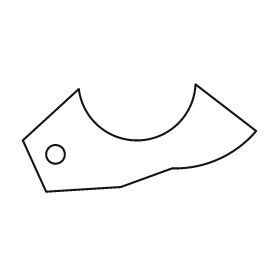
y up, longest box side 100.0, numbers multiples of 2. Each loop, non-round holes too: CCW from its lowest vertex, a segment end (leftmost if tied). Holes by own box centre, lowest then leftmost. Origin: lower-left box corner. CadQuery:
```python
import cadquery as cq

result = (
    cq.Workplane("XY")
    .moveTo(10.0, 0.0)
    .lineTo(42.0, 2.0)
    .lineTo(64.0, 10.0)
    .threePointArc((84.0, 14.0), (100.0, 26.0))
    .lineTo(74.0, 46.0)
    .threePointArc((50.0, 22.0), (24.0, 44.0))
    .lineTo(0.0, 22.0)
    .close()
    .moveTo(14.0, 16.0)
    .circle(4.0)
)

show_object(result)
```